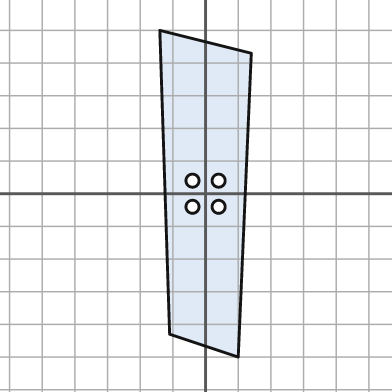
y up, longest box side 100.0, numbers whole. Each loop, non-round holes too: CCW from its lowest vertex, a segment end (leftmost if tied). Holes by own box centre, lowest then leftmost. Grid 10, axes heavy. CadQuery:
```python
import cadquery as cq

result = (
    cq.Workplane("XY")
    .moveTo(10.0, -50.0)
    .lineTo(14.0, 43.0)
    .lineTo(-14.0, 50.0)
    .lineTo(-11.0, -43.0)
    .close()
    .moveTo(-4.0, -4.0)
    .circle(2.0)
    .moveTo(4.0, -4.0)
    .circle(2.0)
    .moveTo(-4.0, 4.0)
    .circle(2.0)
    .moveTo(4.0, 4.0)
    .circle(2.0)
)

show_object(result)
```